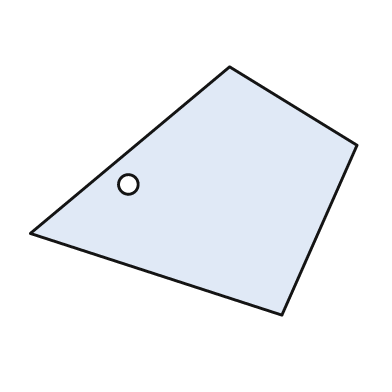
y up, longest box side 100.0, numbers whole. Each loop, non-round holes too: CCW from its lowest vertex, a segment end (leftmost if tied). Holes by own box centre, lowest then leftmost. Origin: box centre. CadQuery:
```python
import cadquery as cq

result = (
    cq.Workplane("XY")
    .moveTo(27.0, -38.0)
    .lineTo(50.0, 14.0)
    .lineTo(11.0, 38.0)
    .lineTo(-50.0, -13.0)
    .close()
    .moveTo(-20.0, 2.0)
    .circle(3.0)
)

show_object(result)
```